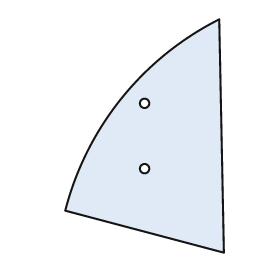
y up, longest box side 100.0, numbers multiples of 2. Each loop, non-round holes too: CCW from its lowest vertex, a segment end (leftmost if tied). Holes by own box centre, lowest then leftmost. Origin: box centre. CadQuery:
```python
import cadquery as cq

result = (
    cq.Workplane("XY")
    .moveTo(34.0, -50.0)
    .lineTo(32.0, 50.0)
    .threePointArc((-10.0, 16.0), (-34.0, -32.0))
    .close()
    .moveTo(0.0, -14.0)
    .circle(2.0)
    .moveTo(0.0, 14.0)
    .circle(2.0)
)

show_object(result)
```